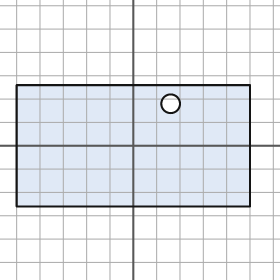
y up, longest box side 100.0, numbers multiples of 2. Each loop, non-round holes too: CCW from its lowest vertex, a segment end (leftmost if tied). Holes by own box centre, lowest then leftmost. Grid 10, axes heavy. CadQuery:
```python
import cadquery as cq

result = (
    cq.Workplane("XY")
    .moveTo(-50.0, -26.0)
    .lineTo(50.0, -26.0)
    .lineTo(50.0, 26.0)
    .lineTo(-50.0, 26.0)
    .close()
    .moveTo(16.0, 18.0)
    .circle(4.0)
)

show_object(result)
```